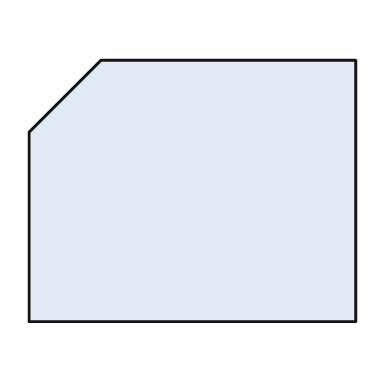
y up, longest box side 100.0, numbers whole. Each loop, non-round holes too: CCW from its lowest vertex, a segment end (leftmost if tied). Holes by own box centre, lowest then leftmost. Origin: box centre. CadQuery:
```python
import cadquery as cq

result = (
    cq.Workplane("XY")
    .moveTo(-50.0, -40.0)
    .lineTo(50.0, -40.0)
    .lineTo(50.0, 40.0)
    .lineTo(-28.0, 40.0)
    .lineTo(-50.0, 18.0)
    .close()
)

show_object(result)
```